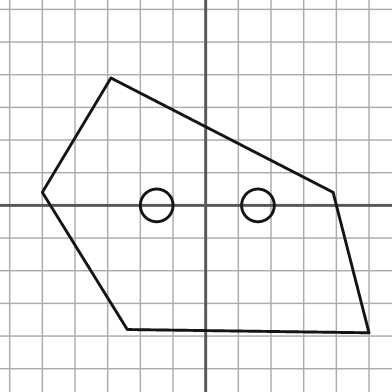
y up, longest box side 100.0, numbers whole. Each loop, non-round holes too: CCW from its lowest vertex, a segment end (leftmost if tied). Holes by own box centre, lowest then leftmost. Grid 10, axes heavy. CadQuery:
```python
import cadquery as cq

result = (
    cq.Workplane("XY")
    .moveTo(50.0, -39.0)
    .lineTo(39.0, 4.0)
    .lineTo(-29.0, 39.0)
    .lineTo(-50.0, 4.0)
    .lineTo(-24.0, -38.0)
    .close()
    .moveTo(-15.0, 0.0)
    .circle(5.0)
    .moveTo(16.0, 0.0)
    .circle(5.0)
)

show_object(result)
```